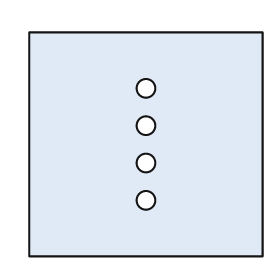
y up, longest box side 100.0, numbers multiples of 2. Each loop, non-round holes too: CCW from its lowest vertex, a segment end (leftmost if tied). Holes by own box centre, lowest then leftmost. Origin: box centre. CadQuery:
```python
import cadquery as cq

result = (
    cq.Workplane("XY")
    .moveTo(-50.0, -48.0)
    .lineTo(50.0, -48.0)
    .lineTo(50.0, 48.0)
    .lineTo(-50.0, 48.0)
    .close()
    .moveTo(0.0, -24.0)
    .circle(4.0)
    .moveTo(0.0, -8.0)
    .circle(4.0)
    .moveTo(0.0, 8.0)
    .circle(4.0)
    .moveTo(0.0, 24.0)
    .circle(4.0)
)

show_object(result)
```